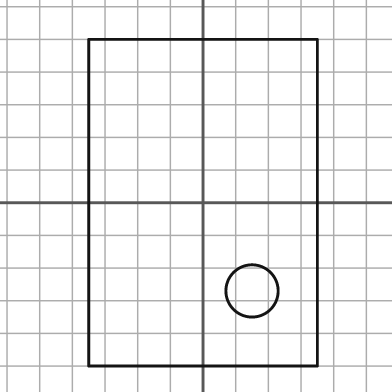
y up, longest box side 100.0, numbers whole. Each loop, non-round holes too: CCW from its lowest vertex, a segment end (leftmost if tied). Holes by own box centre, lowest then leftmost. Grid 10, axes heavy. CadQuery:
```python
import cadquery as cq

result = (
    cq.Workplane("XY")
    .moveTo(-35.0, -50.0)
    .lineTo(35.0, -50.0)
    .lineTo(35.0, 50.0)
    .lineTo(-35.0, 50.0)
    .close()
    .moveTo(15.0, -27.0)
    .circle(8.0)
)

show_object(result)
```